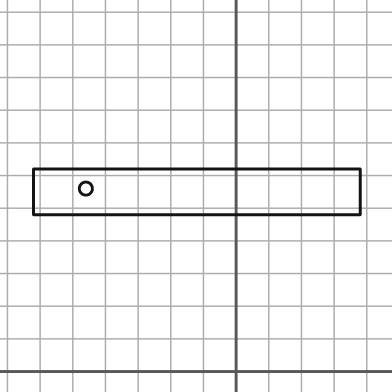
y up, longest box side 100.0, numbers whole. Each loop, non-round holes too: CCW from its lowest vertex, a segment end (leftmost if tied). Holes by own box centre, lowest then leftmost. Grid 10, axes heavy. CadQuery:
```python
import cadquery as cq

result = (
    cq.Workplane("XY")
    .moveTo(-62.0, 48.0)
    .lineTo(38.0, 48.0)
    .lineTo(38.0, 62.0)
    .lineTo(-62.0, 62.0)
    .close()
    .moveTo(-46.0, 56.0)
    .circle(2.0)
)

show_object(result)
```